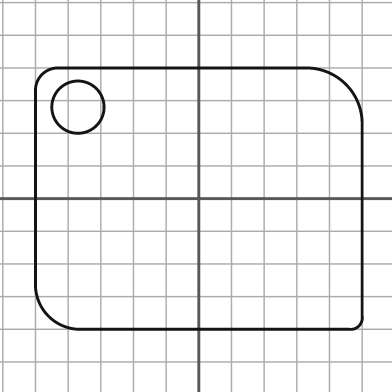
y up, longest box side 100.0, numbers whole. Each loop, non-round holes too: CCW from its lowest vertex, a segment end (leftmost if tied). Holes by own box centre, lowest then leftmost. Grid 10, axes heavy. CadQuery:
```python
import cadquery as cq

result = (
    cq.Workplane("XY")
    .moveTo(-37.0, -40.0)
    .lineTo(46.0, -40.0)
    .threePointArc((49.0, -39.0), (50.0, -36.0))
    .lineTo(50.0, 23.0)
    .threePointArc((45.0, 35.0), (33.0, 40.0))
    .lineTo(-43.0, 40.0)
    .threePointArc((-48.0, 38.0), (-50.0, 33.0))
    .lineTo(-50.0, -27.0)
    .threePointArc((-46.0, -36.0), (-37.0, -40.0))
    .close()
    .moveTo(-37.0, 28.0)
    .circle(8.0)
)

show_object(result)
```